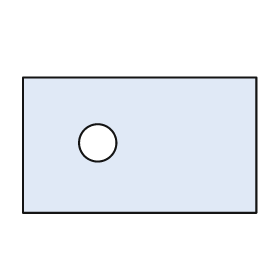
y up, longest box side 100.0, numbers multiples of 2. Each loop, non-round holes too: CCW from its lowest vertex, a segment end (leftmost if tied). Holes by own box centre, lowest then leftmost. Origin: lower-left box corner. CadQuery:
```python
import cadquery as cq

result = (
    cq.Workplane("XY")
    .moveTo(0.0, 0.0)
    .lineTo(100.0, 0.0)
    .lineTo(100.0, 58.0)
    .lineTo(0.0, 58.0)
    .close()
    .moveTo(32.0, 30.0)
    .circle(8.0)
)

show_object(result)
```